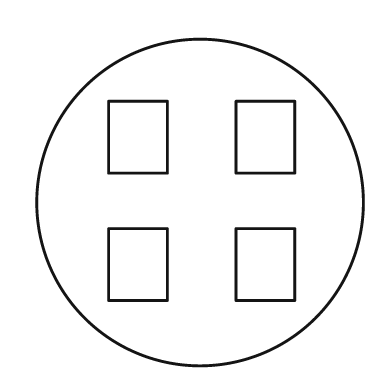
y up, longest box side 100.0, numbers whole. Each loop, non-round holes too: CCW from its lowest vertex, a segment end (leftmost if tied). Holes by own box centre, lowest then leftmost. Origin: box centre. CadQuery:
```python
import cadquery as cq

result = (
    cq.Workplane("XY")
    .moveTo(0.0, 0.0)
    .circle(50.0)
    .moveTo(-28.0, -30.0)
    .lineTo(-10.0, -30.0)
    .lineTo(-10.0, -8.0)
    .lineTo(-28.0, -8.0)
    .close()
    .moveTo(11.0, -30.0)
    .lineTo(29.0, -30.0)
    .lineTo(29.0, -8.0)
    .lineTo(11.0, -8.0)
    .close()
    .moveTo(-28.0, 9.0)
    .lineTo(-10.0, 9.0)
    .lineTo(-10.0, 31.0)
    .lineTo(-28.0, 31.0)
    .close()
    .moveTo(11.0, 9.0)
    .lineTo(29.0, 9.0)
    .lineTo(29.0, 31.0)
    .lineTo(11.0, 31.0)
    .close()
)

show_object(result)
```